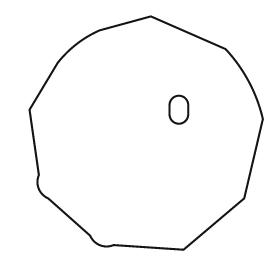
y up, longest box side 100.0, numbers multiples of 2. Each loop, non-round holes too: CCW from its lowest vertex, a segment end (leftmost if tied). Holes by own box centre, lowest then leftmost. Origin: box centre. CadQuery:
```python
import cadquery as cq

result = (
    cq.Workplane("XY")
    .moveTo(16.0, -50.0)
    .lineTo(42.0, -28.0)
    .lineTo(50.0, 6.0)
    .threePointArc((44.0, 22.0), (34.0, 36.0))
    .lineTo(2.0, 50.0)
    .lineTo(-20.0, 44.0)
    .threePointArc((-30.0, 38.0), (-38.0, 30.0))
    .lineTo(-50.0, 10.0)
    .lineTo(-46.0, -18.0)
    .threePointArc((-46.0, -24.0), (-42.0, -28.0))
    .lineTo(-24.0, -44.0)
    .threePointArc((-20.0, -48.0), (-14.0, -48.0))
    .close()
    .moveTo(10.0, 8.0)
    .threePointArc((14.0, 4.0), (18.0, 8.0))
    .lineTo(18.0, 12.0)
    .threePointArc((14.0, 16.0), (10.0, 12.0))
    .close()
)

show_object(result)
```